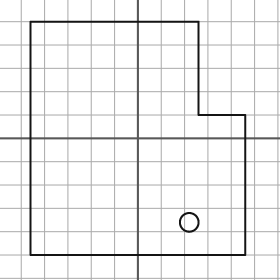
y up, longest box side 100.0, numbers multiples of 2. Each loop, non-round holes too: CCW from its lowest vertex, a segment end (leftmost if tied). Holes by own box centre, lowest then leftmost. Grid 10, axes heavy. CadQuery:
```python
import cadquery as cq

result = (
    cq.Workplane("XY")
    .moveTo(-46.0, -50.0)
    .lineTo(46.0, -50.0)
    .lineTo(46.0, 10.0)
    .lineTo(26.0, 10.0)
    .lineTo(26.0, 50.0)
    .lineTo(-46.0, 50.0)
    .close()
    .moveTo(22.0, -36.0)
    .circle(4.0)
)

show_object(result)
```